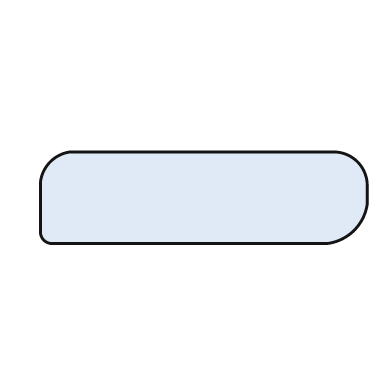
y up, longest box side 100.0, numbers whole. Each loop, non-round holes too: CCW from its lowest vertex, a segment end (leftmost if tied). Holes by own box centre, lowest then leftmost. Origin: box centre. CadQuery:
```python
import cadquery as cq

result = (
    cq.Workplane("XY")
    .moveTo(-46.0, -14.0)
    .lineTo(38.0, -14.0)
    .threePointArc((46.0, -10.0), (50.0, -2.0))
    .lineTo(50.0, 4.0)
    .threePointArc((47.0, 11.0), (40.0, 14.0))
    .lineTo(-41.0, 14.0)
    .threePointArc((-47.0, 11.0), (-50.0, 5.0))
    .lineTo(-50.0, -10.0)
    .threePointArc((-49.0, -13.0), (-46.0, -14.0))
    .close()
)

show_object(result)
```